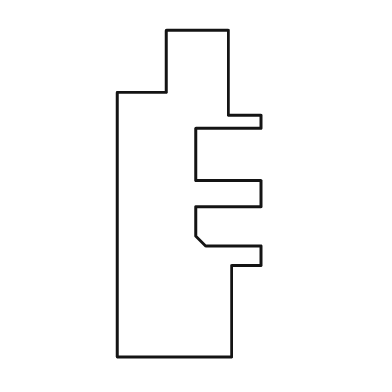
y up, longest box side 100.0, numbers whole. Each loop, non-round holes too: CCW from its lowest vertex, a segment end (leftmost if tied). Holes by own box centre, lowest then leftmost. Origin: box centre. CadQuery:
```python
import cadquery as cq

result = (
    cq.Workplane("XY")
    .moveTo(-22.0, -50.0)
    .lineTo(13.0, -50.0)
    .lineTo(13.0, -22.0)
    .lineTo(22.0, -22.0)
    .lineTo(22.0, -16.0)
    .lineTo(5.0, -16.0)
    .lineTo(2.0, -13.0)
    .lineTo(2.0, -4.0)
    .lineTo(22.0, -4.0)
    .lineTo(22.0, 4.0)
    .lineTo(2.0, 4.0)
    .lineTo(2.0, 20.0)
    .lineTo(22.0, 20.0)
    .lineTo(22.0, 24.0)
    .lineTo(12.0, 24.0)
    .lineTo(12.0, 50.0)
    .lineTo(-7.0, 50.0)
    .lineTo(-7.0, 31.0)
    .lineTo(-22.0, 31.0)
    .close()
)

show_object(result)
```